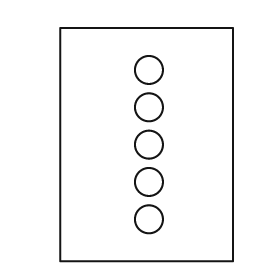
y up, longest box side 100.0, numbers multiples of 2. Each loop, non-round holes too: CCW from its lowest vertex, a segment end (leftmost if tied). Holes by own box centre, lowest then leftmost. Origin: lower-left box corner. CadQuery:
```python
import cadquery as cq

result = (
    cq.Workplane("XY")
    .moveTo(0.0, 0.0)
    .lineTo(74.0, 0.0)
    .lineTo(74.0, 100.0)
    .lineTo(0.0, 100.0)
    .close()
    .moveTo(38.0, 18.0)
    .circle(6.0)
    .moveTo(38.0, 34.0)
    .circle(6.0)
    .moveTo(38.0, 50.0)
    .circle(6.0)
    .moveTo(38.0, 66.0)
    .circle(6.0)
    .moveTo(38.0, 82.0)
    .circle(6.0)
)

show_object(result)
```